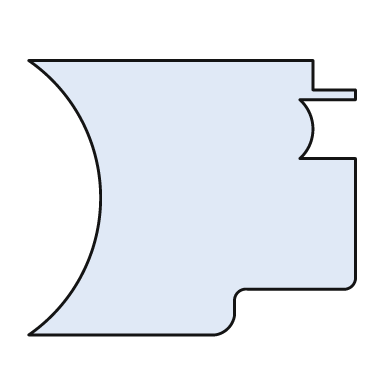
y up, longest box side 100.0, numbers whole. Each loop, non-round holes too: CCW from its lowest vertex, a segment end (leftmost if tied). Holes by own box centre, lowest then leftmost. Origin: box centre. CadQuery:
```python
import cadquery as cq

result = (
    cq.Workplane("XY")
    .moveTo(-50.0, -42.0)
    .lineTo(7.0, -42.0)
    .threePointArc((11.0, -40.0), (13.0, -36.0))
    .lineTo(13.0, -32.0)
    .threePointArc((14.0, -29.0), (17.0, -28.0))
    .lineTo(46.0, -28.0)
    .threePointArc((49.0, -27.0), (50.0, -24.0))
    .lineTo(50.0, 12.0)
    .lineTo(33.0, 12.0)
    .threePointArc((37.0, 21.0), (33.0, 30.0))
    .lineTo(50.0, 30.0)
    .lineTo(50.0, 33.0)
    .lineTo(37.0, 33.0)
    .lineTo(37.0, 42.0)
    .lineTo(-50.0, 42.0)
    .threePointArc((-28.0, 0.0), (-50.0, -42.0))
    .close()
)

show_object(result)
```